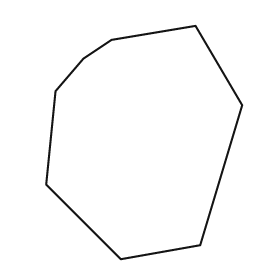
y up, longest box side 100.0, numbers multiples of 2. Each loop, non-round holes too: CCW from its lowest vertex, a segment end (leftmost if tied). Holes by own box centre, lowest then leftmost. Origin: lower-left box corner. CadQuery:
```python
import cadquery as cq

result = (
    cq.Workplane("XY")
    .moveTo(32.0, 0.0)
    .lineTo(66.0, 6.0)
    .lineTo(84.0, 66.0)
    .lineTo(64.0, 100.0)
    .lineTo(28.0, 94.0)
    .lineTo(16.0, 86.0)
    .lineTo(4.0, 72.0)
    .lineTo(0.0, 32.0)
    .close()
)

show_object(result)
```